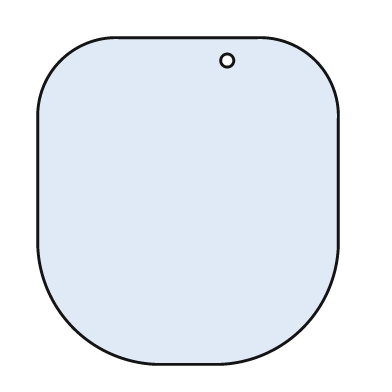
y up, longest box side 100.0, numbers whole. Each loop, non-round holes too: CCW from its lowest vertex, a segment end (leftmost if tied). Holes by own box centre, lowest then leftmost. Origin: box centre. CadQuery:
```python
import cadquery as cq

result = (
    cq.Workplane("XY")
    .moveTo(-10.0, -50.0)
    .lineTo(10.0, -50.0)
    .threePointArc((35.0, -39.0), (46.0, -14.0))
    .lineTo(46.0, 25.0)
    .threePointArc((39.0, 43.0), (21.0, 50.0))
    .lineTo(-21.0, 50.0)
    .threePointArc((-39.0, 43.0), (-46.0, 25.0))
    .lineTo(-46.0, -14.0)
    .threePointArc((-35.0, -39.0), (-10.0, -50.0))
    .close()
    .moveTo(12.0, 43.0)
    .circle(2.0)
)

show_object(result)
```